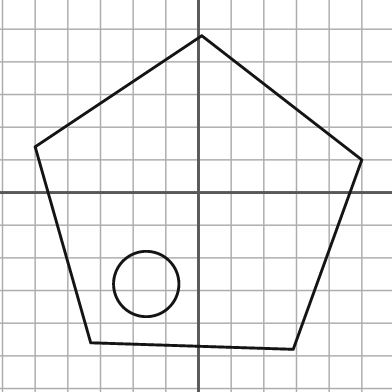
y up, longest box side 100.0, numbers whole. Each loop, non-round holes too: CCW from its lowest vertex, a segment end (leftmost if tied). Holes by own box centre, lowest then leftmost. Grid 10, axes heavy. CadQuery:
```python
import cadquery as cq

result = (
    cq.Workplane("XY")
    .moveTo(29.0, -48.0)
    .lineTo(50.0, 10.0)
    .lineTo(1.0, 48.0)
    .lineTo(-50.0, 14.0)
    .lineTo(-33.0, -46.0)
    .close()
    .moveTo(-16.0, -28.0)
    .circle(10.0)
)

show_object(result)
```